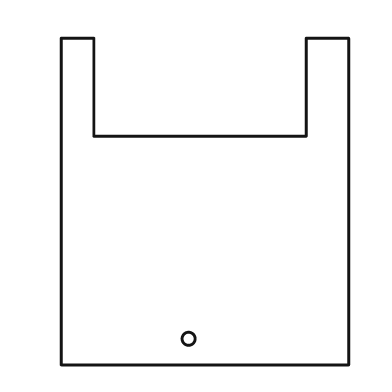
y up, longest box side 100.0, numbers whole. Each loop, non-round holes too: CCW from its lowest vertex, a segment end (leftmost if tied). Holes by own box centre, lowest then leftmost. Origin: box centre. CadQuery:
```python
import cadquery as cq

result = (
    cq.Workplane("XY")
    .moveTo(-44.0, -50.0)
    .lineTo(44.0, -50.0)
    .lineTo(44.0, 50.0)
    .lineTo(31.0, 50.0)
    .lineTo(31.0, 20.0)
    .lineTo(-34.0, 20.0)
    .lineTo(-34.0, 50.0)
    .lineTo(-44.0, 50.0)
    .close()
    .moveTo(-5.0, -42.0)
    .circle(2.0)
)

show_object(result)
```